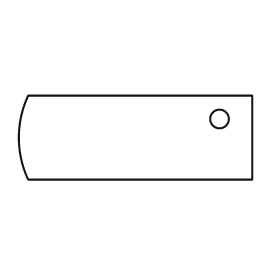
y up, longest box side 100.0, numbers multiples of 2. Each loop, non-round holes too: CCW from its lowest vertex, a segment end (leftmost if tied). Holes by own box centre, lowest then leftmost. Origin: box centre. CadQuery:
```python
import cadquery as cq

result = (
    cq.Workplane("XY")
    .moveTo(-46.0, -18.0)
    .lineTo(50.0, -18.0)
    .lineTo(50.0, 18.0)
    .lineTo(-46.0, 18.0)
    .threePointArc((-50.0, 0.0), (-46.0, -18.0))
    .close()
    .moveTo(36.0, 8.0)
    .circle(4.0)
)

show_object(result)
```